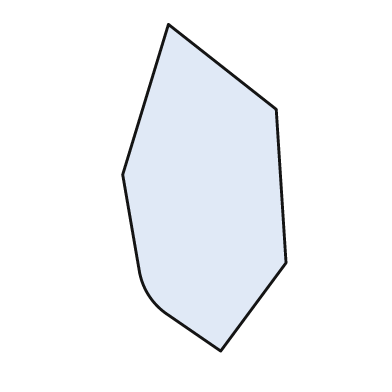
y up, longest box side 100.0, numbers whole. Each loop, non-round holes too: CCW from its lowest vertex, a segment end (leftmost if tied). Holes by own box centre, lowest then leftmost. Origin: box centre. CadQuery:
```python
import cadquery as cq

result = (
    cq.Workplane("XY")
    .moveTo(5.0, -50.0)
    .lineTo(25.0, -23.0)
    .lineTo(22.0, 24.0)
    .lineTo(-11.0, 50.0)
    .lineTo(-25.0, 4.0)
    .lineTo(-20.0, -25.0)
    .threePointArc((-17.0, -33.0), (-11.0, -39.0))
    .close()
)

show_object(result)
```